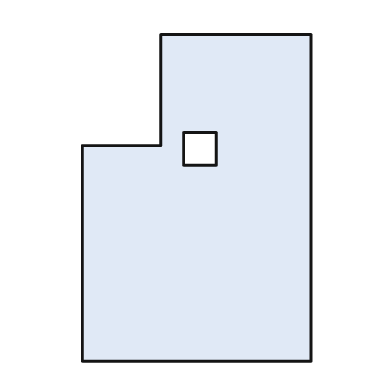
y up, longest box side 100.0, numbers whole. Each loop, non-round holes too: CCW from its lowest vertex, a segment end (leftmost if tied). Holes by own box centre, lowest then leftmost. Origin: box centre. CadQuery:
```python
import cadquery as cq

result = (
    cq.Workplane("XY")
    .moveTo(-35.0, -50.0)
    .lineTo(35.0, -50.0)
    .lineTo(35.0, 50.0)
    .lineTo(-11.0, 50.0)
    .lineTo(-11.0, 16.0)
    .lineTo(-35.0, 16.0)
    .close()
    .moveTo(-4.0, 10.0)
    .lineTo(6.0, 10.0)
    .lineTo(6.0, 20.0)
    .lineTo(-4.0, 20.0)
    .close()
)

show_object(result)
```